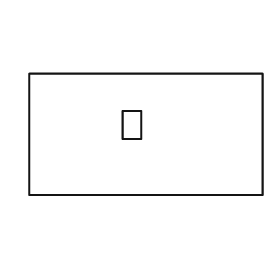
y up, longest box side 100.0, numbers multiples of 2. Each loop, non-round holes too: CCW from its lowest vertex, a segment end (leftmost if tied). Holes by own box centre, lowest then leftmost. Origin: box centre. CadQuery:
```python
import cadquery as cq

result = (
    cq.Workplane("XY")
    .moveTo(-50.0, -26.0)
    .lineTo(50.0, -26.0)
    .lineTo(50.0, 26.0)
    .lineTo(-50.0, 26.0)
    .close()
    .moveTo(-10.0, -2.0)
    .lineTo(-2.0, -2.0)
    .lineTo(-2.0, 10.0)
    .lineTo(-10.0, 10.0)
    .close()
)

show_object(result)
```